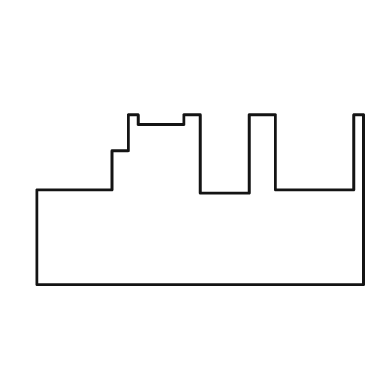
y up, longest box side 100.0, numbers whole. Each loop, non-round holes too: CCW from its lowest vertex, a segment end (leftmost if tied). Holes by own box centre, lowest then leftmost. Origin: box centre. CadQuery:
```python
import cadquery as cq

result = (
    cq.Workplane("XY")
    .moveTo(-50.0, -26.0)
    .lineTo(50.0, -26.0)
    .lineTo(50.0, 26.0)
    .lineTo(47.0, 26.0)
    .lineTo(47.0, 3.0)
    .lineTo(23.0, 3.0)
    .lineTo(23.0, 26.0)
    .lineTo(15.0, 26.0)
    .lineTo(15.0, 2.0)
    .lineTo(0.0, 2.0)
    .lineTo(0.0, 26.0)
    .lineTo(-5.0, 26.0)
    .lineTo(-5.0, 23.0)
    .lineTo(-19.0, 23.0)
    .lineTo(-19.0, 26.0)
    .lineTo(-22.0, 26.0)
    .lineTo(-22.0, 15.0)
    .lineTo(-27.0, 15.0)
    .lineTo(-27.0, 3.0)
    .lineTo(-50.0, 3.0)
    .close()
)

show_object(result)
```